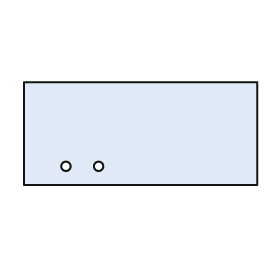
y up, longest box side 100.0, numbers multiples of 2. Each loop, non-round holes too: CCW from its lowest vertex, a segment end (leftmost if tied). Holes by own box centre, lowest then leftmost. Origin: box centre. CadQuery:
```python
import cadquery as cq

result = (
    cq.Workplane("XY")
    .moveTo(-50.0, -22.0)
    .lineTo(50.0, -22.0)
    .lineTo(50.0, 22.0)
    .lineTo(-50.0, 22.0)
    .close()
    .moveTo(-32.0, -14.0)
    .circle(2.0)
    .moveTo(-18.0, -14.0)
    .circle(2.0)
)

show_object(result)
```